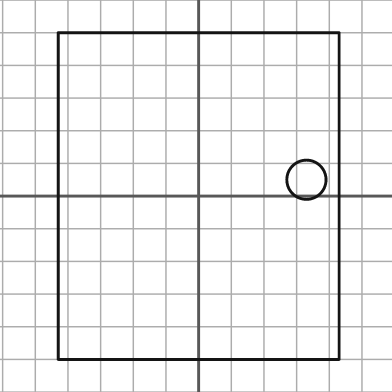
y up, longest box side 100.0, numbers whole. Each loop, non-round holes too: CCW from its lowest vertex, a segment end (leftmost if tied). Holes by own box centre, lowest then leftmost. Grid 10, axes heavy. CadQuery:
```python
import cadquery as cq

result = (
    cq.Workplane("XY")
    .moveTo(-43.0, -50.0)
    .lineTo(43.0, -50.0)
    .lineTo(43.0, 50.0)
    .lineTo(-43.0, 50.0)
    .close()
    .moveTo(33.0, 5.0)
    .circle(6.0)
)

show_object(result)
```